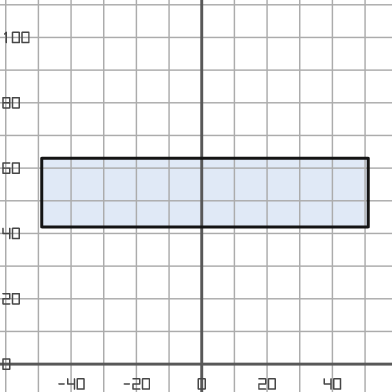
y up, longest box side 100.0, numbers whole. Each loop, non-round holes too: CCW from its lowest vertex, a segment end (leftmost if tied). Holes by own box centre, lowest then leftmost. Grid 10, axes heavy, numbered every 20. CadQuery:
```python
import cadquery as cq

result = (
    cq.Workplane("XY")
    .moveTo(-49.0, 42.0)
    .lineTo(51.0, 42.0)
    .lineTo(51.0, 63.0)
    .lineTo(-49.0, 63.0)
    .close()
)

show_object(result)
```